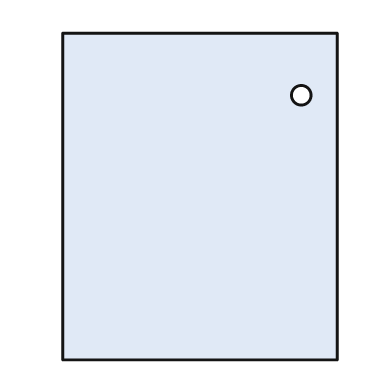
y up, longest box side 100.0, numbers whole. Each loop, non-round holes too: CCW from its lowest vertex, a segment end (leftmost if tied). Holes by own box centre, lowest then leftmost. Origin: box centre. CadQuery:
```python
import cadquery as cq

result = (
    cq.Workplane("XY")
    .moveTo(-42.0, -50.0)
    .lineTo(42.0, -50.0)
    .lineTo(42.0, 50.0)
    .lineTo(-42.0, 50.0)
    .close()
    .moveTo(31.0, 31.0)
    .circle(3.0)
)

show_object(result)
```